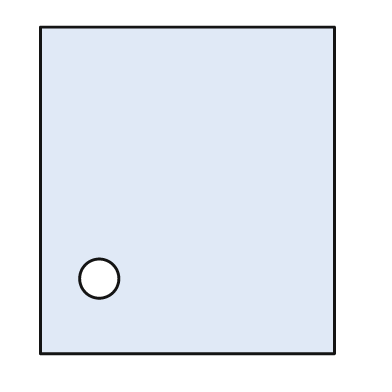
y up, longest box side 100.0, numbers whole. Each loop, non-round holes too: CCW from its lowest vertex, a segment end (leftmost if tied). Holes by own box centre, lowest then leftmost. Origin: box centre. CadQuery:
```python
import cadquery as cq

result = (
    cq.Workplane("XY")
    .moveTo(-45.0, -50.0)
    .lineTo(45.0, -50.0)
    .lineTo(45.0, 50.0)
    .lineTo(-45.0, 50.0)
    .close()
    .moveTo(-27.0, -27.0)
    .circle(6.0)
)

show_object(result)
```